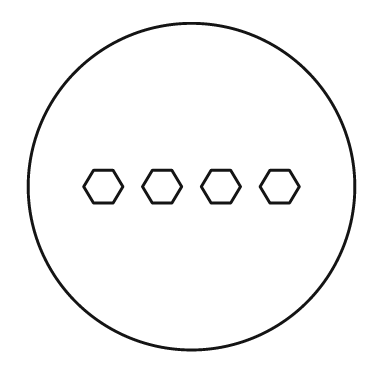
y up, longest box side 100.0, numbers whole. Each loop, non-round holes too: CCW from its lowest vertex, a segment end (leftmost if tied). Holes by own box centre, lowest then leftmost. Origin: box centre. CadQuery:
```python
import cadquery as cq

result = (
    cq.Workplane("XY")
    .moveTo(0.0, 0.0)
    .circle(50.0)
    .moveTo(-30.0, -5.0)
    .lineTo(-24.0, -5.0)
    .lineTo(-21.0, 0.0)
    .lineTo(-24.0, 5.0)
    .lineTo(-30.0, 5.0)
    .lineTo(-33.0, 0.0)
    .close()
    .moveTo(-12.0, -5.0)
    .lineTo(-6.0, -5.0)
    .lineTo(-3.0, 0.0)
    .lineTo(-6.0, 5.0)
    .lineTo(-12.0, 5.0)
    .lineTo(-15.0, 0.0)
    .close()
    .moveTo(6.0, -5.0)
    .lineTo(12.0, -5.0)
    .lineTo(15.0, 0.0)
    .lineTo(12.0, 5.0)
    .lineTo(6.0, 5.0)
    .lineTo(3.0, 0.0)
    .close()
    .moveTo(24.0, -5.0)
    .lineTo(30.0, -5.0)
    .lineTo(33.0, 0.0)
    .lineTo(30.0, 5.0)
    .lineTo(24.0, 5.0)
    .lineTo(21.0, 0.0)
    .close()
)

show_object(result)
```